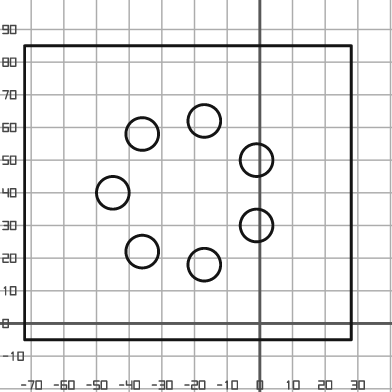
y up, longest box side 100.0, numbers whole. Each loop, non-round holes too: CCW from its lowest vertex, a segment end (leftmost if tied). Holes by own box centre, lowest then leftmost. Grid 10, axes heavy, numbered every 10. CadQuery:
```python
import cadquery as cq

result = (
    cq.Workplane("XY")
    .moveTo(-72.0, -5.0)
    .lineTo(28.0, -5.0)
    .lineTo(28.0, 85.0)
    .lineTo(-72.0, 85.0)
    .close()
    .moveTo(-17.0, 18.0)
    .circle(5.0)
    .moveTo(-36.0, 22.0)
    .circle(5.0)
    .moveTo(-1.0, 30.0)
    .circle(5.0)
    .moveTo(-45.0, 40.0)
    .circle(5.0)
    .moveTo(-1.0, 50.0)
    .circle(5.0)
    .moveTo(-36.0, 58.0)
    .circle(5.0)
    .moveTo(-17.0, 62.0)
    .circle(5.0)
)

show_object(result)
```